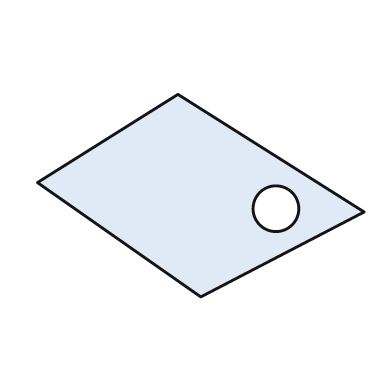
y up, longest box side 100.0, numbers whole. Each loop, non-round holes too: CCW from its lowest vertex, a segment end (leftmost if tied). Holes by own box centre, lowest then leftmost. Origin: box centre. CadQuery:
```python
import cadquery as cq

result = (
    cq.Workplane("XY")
    .moveTo(0.0, -31.0)
    .lineTo(50.0, -5.0)
    .lineTo(-7.0, 31.0)
    .lineTo(-50.0, 4.0)
    .close()
    .moveTo(23.0, -4.0)
    .circle(7.0)
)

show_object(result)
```